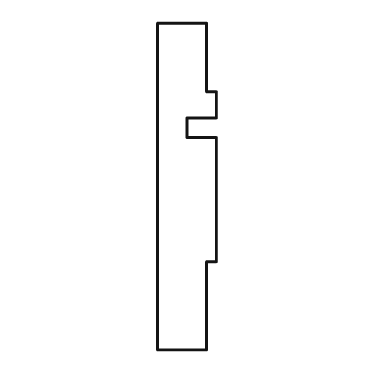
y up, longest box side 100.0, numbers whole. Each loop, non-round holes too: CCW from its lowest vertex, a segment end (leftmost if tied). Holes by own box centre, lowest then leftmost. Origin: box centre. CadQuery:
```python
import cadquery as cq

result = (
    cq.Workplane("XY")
    .moveTo(-9.0, -50.0)
    .lineTo(6.0, -50.0)
    .lineTo(6.0, -23.0)
    .lineTo(9.0, -23.0)
    .lineTo(9.0, 15.0)
    .lineTo(0.0, 15.0)
    .lineTo(0.0, 21.0)
    .lineTo(9.0, 21.0)
    .lineTo(9.0, 29.0)
    .lineTo(6.0, 29.0)
    .lineTo(6.0, 50.0)
    .lineTo(-9.0, 50.0)
    .close()
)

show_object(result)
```